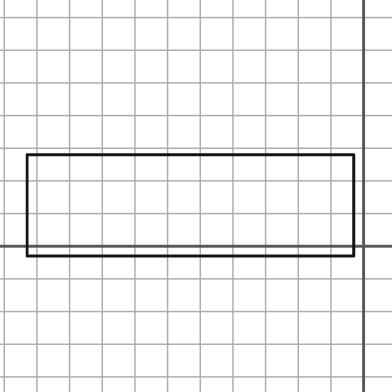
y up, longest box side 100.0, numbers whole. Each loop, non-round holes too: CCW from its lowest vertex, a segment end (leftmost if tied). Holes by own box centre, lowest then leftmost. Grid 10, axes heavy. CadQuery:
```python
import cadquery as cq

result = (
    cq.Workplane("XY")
    .moveTo(-103.0, -3.0)
    .lineTo(-3.0, -3.0)
    .lineTo(-3.0, 28.0)
    .lineTo(-103.0, 28.0)
    .close()
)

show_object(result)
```